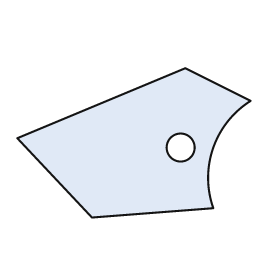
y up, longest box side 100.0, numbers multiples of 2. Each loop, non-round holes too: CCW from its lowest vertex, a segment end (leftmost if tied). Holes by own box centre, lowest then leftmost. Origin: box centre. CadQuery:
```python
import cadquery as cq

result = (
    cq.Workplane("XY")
    .moveTo(-18.0, -32.0)
    .lineTo(34.0, -28.0)
    .threePointArc((34.0, -2.0), (50.0, 18.0))
    .lineTo(22.0, 32.0)
    .lineTo(-50.0, 2.0)
    .close()
    .moveTo(20.0, -2.0)
    .circle(6.0)
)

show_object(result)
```